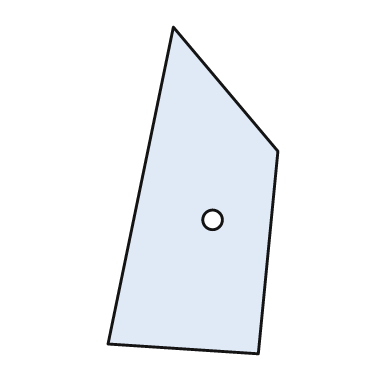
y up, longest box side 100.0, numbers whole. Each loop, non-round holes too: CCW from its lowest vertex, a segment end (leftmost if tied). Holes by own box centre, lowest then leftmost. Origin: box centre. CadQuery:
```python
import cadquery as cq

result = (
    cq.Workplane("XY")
    .moveTo(20.0, -50.0)
    .lineTo(26.0, 12.0)
    .lineTo(-6.0, 50.0)
    .lineTo(-26.0, -47.0)
    .close()
    .moveTo(6.0, -9.0)
    .circle(3.0)
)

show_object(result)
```